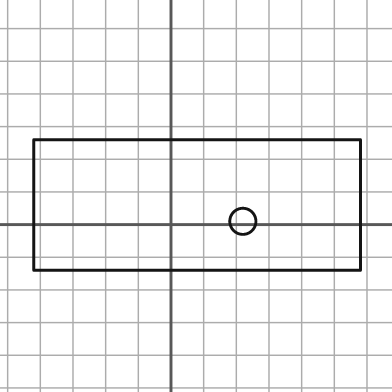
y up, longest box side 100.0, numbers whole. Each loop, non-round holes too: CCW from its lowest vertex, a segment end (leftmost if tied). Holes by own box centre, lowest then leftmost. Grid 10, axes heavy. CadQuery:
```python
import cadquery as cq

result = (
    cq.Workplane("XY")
    .moveTo(-42.0, -14.0)
    .lineTo(58.0, -14.0)
    .lineTo(58.0, 26.0)
    .lineTo(-42.0, 26.0)
    .close()
    .moveTo(22.0, 1.0)
    .circle(4.0)
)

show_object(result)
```